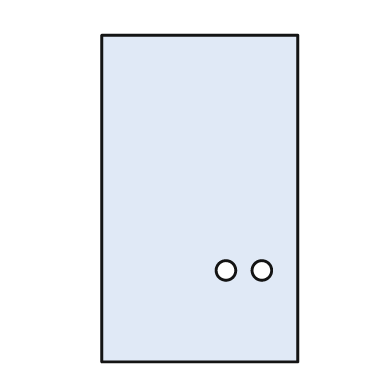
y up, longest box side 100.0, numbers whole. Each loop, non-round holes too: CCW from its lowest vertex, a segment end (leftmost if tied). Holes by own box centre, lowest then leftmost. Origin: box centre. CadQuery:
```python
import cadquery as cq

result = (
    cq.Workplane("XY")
    .moveTo(-30.0, -50.0)
    .lineTo(30.0, -50.0)
    .lineTo(30.0, 50.0)
    .lineTo(-30.0, 50.0)
    .close()
    .moveTo(8.0, -22.0)
    .circle(3.0)
    .moveTo(19.0, -22.0)
    .circle(3.0)
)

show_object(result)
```